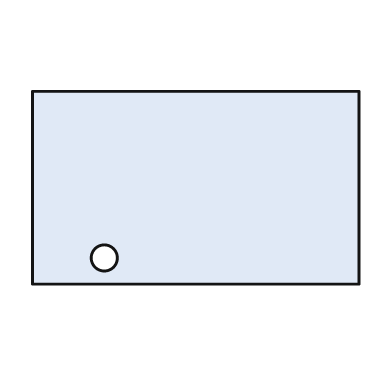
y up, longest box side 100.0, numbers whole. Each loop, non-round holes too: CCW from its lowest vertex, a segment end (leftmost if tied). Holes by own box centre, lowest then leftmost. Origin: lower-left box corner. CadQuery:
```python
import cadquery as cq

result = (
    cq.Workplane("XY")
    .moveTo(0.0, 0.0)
    .lineTo(100.0, 0.0)
    .lineTo(100.0, 59.0)
    .lineTo(0.0, 59.0)
    .close()
    .moveTo(22.0, 8.0)
    .circle(4.0)
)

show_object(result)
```